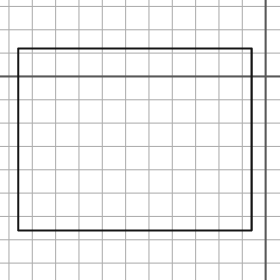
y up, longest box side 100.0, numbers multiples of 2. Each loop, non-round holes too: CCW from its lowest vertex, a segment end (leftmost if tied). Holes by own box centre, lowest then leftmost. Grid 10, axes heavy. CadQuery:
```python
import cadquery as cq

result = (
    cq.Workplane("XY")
    .moveTo(-106.0, -66.0)
    .lineTo(-6.0, -66.0)
    .lineTo(-6.0, 12.0)
    .lineTo(-106.0, 12.0)
    .close()
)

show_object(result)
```